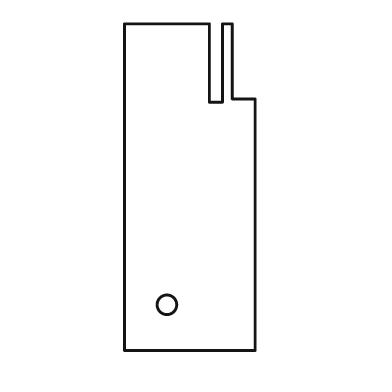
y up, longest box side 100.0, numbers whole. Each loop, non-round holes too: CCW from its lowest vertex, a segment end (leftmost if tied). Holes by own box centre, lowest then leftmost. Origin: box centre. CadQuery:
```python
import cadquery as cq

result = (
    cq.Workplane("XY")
    .moveTo(-20.0, -50.0)
    .lineTo(20.0, -50.0)
    .lineTo(20.0, 27.0)
    .lineTo(13.0, 27.0)
    .lineTo(13.0, 50.0)
    .lineTo(10.0, 50.0)
    .lineTo(10.0, 26.0)
    .lineTo(6.0, 26.0)
    .lineTo(6.0, 50.0)
    .lineTo(-20.0, 50.0)
    .close()
    .moveTo(-7.0, -36.0)
    .circle(3.0)
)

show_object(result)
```